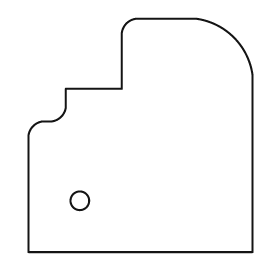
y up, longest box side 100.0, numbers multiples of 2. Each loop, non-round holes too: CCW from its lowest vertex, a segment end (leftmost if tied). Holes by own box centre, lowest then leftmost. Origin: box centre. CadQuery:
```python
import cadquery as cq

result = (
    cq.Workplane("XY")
    .moveTo(-48.0, -50.0)
    .lineTo(48.0, -50.0)
    .lineTo(48.0, 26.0)
    .threePointArc((40.0, 42.0), (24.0, 50.0))
    .lineTo(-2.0, 50.0)
    .threePointArc((-6.0, 48.0), (-8.0, 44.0))
    .lineTo(-8.0, 20.0)
    .lineTo(-32.0, 20.0)
    .lineTo(-32.0, 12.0)
    .threePointArc((-34.0, 8.0), (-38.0, 6.0))
    .lineTo(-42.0, 6.0)
    .threePointArc((-46.0, 4.0), (-48.0, 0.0))
    .close()
    .moveTo(-26.0, -28.0)
    .circle(4.0)
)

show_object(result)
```